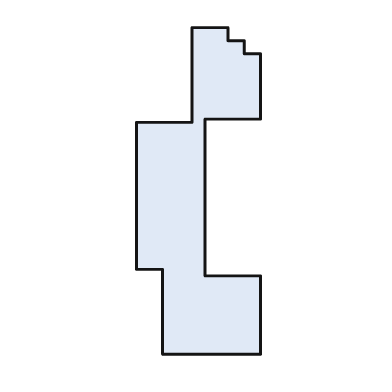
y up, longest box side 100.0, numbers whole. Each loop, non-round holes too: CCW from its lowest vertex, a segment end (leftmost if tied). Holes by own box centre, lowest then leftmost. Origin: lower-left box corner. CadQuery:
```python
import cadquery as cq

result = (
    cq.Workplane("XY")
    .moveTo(8.0, 0.0)
    .lineTo(38.0, 0.0)
    .lineTo(38.0, 24.0)
    .lineTo(21.0, 24.0)
    .lineTo(21.0, 72.0)
    .lineTo(38.0, 72.0)
    .lineTo(38.0, 92.0)
    .lineTo(33.0, 92.0)
    .lineTo(33.0, 96.0)
    .lineTo(28.0, 96.0)
    .lineTo(28.0, 100.0)
    .lineTo(17.0, 100.0)
    .lineTo(17.0, 71.0)
    .lineTo(0.0, 71.0)
    .lineTo(0.0, 26.0)
    .lineTo(8.0, 26.0)
    .close()
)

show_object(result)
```